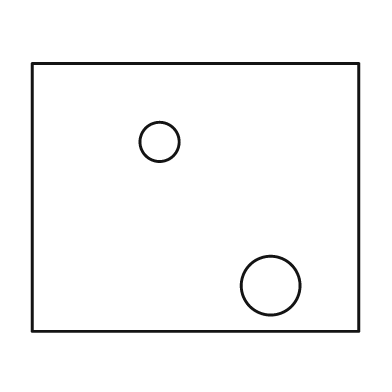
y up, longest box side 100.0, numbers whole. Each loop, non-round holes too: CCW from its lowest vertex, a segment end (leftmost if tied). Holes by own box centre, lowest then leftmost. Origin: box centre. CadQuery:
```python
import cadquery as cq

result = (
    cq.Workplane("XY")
    .moveTo(-50.0, -41.0)
    .lineTo(50.0, -41.0)
    .lineTo(50.0, 41.0)
    .lineTo(-50.0, 41.0)
    .close()
    .moveTo(23.0, -27.0)
    .circle(9.0)
    .moveTo(-11.0, 17.0)
    .circle(6.0)
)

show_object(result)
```